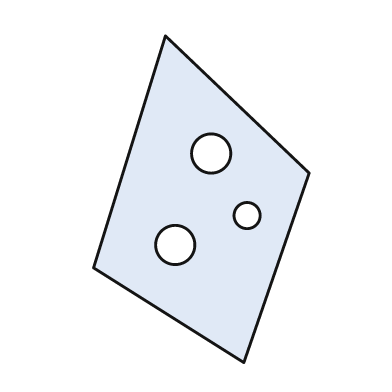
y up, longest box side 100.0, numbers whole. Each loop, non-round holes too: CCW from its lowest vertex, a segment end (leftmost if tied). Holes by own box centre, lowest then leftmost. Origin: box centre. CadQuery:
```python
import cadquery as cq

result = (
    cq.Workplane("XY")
    .moveTo(13.0, -50.0)
    .lineTo(33.0, 8.0)
    .lineTo(-11.0, 50.0)
    .lineTo(-33.0, -21.0)
    .close()
    .moveTo(-8.0, -14.0)
    .circle(6.0)
    .moveTo(14.0, -5.0)
    .circle(4.0)
    .moveTo(3.0, 14.0)
    .circle(6.0)
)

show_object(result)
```